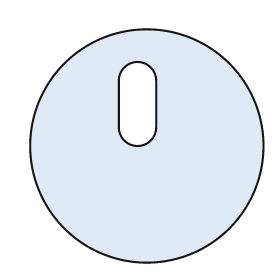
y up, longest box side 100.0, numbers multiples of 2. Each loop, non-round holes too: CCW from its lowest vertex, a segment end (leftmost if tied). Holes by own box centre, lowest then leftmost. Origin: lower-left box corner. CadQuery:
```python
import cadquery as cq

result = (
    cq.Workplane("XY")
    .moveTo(50.0, 50.0)
    .circle(50.0)
    .moveTo(38.0, 58.0)
    .threePointArc((46.0, 50.0), (54.0, 58.0))
    .lineTo(54.0, 78.0)
    .threePointArc((46.0, 86.0), (38.0, 78.0))
    .close()
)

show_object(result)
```